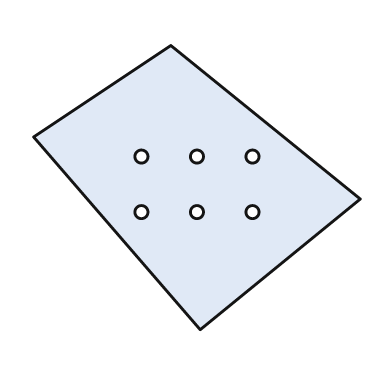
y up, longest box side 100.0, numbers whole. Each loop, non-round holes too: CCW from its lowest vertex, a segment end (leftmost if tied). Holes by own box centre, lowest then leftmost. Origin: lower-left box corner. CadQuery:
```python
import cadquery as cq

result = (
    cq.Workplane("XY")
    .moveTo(51.0, 0.0)
    .lineTo(100.0, 40.0)
    .lineTo(42.0, 87.0)
    .lineTo(0.0, 59.0)
    .close()
    .moveTo(33.0, 36.0)
    .circle(2.0)
    .moveTo(50.0, 36.0)
    .circle(2.0)
    .moveTo(67.0, 36.0)
    .circle(2.0)
    .moveTo(33.0, 53.0)
    .circle(2.0)
    .moveTo(50.0, 53.0)
    .circle(2.0)
    .moveTo(67.0, 53.0)
    .circle(2.0)
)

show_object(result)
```